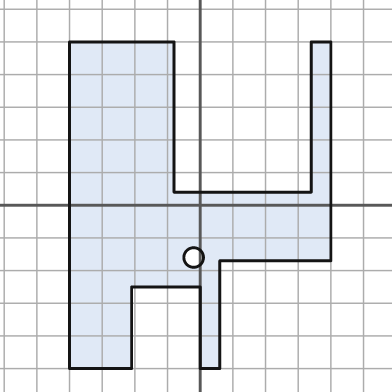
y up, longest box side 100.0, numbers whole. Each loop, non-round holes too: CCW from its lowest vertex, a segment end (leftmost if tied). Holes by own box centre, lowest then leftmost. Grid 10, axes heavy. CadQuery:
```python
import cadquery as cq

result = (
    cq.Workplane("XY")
    .moveTo(-40.0, -50.0)
    .lineTo(-21.0, -50.0)
    .lineTo(-21.0, -25.0)
    .lineTo(0.0, -25.0)
    .lineTo(0.0, -50.0)
    .lineTo(6.0, -50.0)
    .lineTo(6.0, -17.0)
    .lineTo(40.0, -17.0)
    .lineTo(40.0, 50.0)
    .lineTo(34.0, 50.0)
    .lineTo(34.0, 4.0)
    .lineTo(-8.0, 4.0)
    .lineTo(-8.0, 50.0)
    .lineTo(-40.0, 50.0)
    .close()
    .moveTo(-2.0, -16.0)
    .circle(3.0)
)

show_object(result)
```